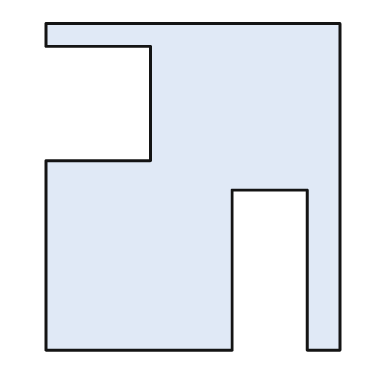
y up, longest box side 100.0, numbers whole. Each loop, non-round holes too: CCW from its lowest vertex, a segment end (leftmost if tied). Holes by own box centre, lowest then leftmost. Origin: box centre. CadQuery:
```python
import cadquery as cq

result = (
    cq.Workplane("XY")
    .moveTo(-45.0, -50.0)
    .lineTo(12.0, -50.0)
    .lineTo(12.0, -1.0)
    .lineTo(35.0, -1.0)
    .lineTo(35.0, -50.0)
    .lineTo(45.0, -50.0)
    .lineTo(45.0, 50.0)
    .lineTo(-45.0, 50.0)
    .lineTo(-45.0, 43.0)
    .lineTo(-13.0, 43.0)
    .lineTo(-13.0, 8.0)
    .lineTo(-45.0, 8.0)
    .close()
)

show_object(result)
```